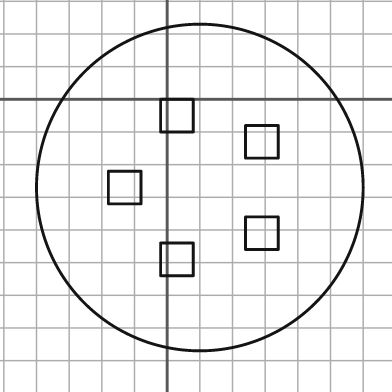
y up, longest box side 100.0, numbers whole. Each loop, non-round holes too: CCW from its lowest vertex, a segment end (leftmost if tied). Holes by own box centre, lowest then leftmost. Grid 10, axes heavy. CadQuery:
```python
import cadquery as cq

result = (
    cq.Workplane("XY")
    .moveTo(10.0, -27.0)
    .circle(50.0)
    .moveTo(-2.0, -54.0)
    .lineTo(8.0, -54.0)
    .lineTo(8.0, -44.0)
    .lineTo(-2.0, -44.0)
    .close()
    .moveTo(24.0, -46.0)
    .lineTo(34.0, -46.0)
    .lineTo(34.0, -36.0)
    .lineTo(24.0, -36.0)
    .close()
    .moveTo(-18.0, -32.0)
    .lineTo(-8.0, -32.0)
    .lineTo(-8.0, -22.0)
    .lineTo(-18.0, -22.0)
    .close()
    .moveTo(24.0, -18.0)
    .lineTo(34.0, -18.0)
    .lineTo(34.0, -8.0)
    .lineTo(24.0, -8.0)
    .close()
    .moveTo(-2.0, -10.0)
    .lineTo(8.0, -10.0)
    .lineTo(8.0, 0.0)
    .lineTo(-2.0, 0.0)
    .close()
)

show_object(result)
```